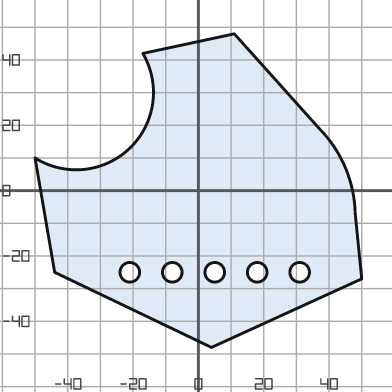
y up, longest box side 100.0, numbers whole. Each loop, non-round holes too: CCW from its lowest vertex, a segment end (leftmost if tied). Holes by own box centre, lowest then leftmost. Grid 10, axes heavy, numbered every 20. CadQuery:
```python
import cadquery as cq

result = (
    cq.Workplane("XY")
    .moveTo(4.0, -48.0)
    .lineTo(50.0, -27.0)
    .lineTo(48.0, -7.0)
    .threePointArc((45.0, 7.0), (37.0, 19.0))
    .lineTo(11.0, 48.0)
    .lineTo(-17.0, 42.0)
    .threePointArc((-21.0, 13.0), (-50.0, 10.0))
    .lineTo(-44.0, -25.0)
    .close()
    .moveTo(-21.0, -25.0)
    .circle(3.0)
    .moveTo(-8.0, -25.0)
    .circle(3.0)
    .moveTo(5.0, -25.0)
    .circle(3.0)
    .moveTo(18.0, -25.0)
    .circle(3.0)
    .moveTo(31.0, -25.0)
    .circle(3.0)
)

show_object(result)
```